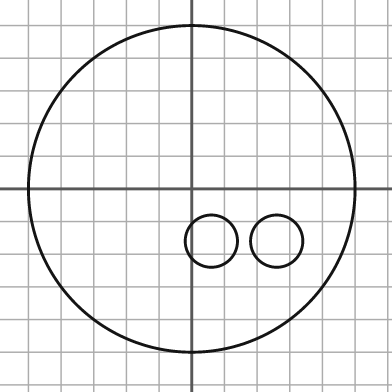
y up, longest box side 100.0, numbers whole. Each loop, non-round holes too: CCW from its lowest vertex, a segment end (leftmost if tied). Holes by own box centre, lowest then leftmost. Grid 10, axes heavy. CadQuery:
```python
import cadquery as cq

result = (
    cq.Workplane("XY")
    .moveTo(0.0, 0.0)
    .circle(50.0)
    .moveTo(6.0, -16.0)
    .circle(8.0)
    .moveTo(26.0, -16.0)
    .circle(8.0)
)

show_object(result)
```